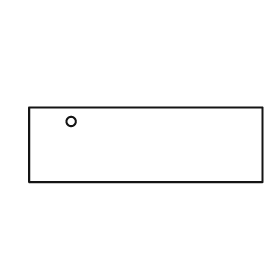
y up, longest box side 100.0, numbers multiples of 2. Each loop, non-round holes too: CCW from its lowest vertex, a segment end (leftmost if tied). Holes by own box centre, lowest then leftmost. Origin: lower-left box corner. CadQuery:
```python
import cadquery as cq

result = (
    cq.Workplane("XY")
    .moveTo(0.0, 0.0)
    .lineTo(100.0, 0.0)
    .lineTo(100.0, 32.0)
    .lineTo(0.0, 32.0)
    .close()
    .moveTo(18.0, 26.0)
    .circle(2.0)
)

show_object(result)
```